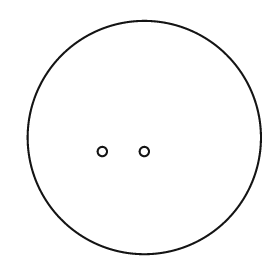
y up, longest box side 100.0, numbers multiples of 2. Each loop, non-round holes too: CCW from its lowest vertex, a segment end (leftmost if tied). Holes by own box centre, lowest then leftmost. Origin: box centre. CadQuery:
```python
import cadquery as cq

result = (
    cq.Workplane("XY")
    .moveTo(0.0, 0.0)
    .circle(50.0)
    .moveTo(-18.0, -6.0)
    .circle(2.0)
    .moveTo(0.0, -6.0)
    .circle(2.0)
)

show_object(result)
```